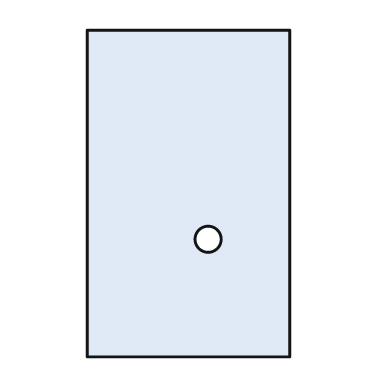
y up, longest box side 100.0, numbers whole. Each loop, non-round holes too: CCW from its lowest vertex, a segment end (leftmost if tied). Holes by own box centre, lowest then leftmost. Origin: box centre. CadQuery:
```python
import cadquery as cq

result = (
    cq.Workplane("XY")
    .moveTo(-31.0, -50.0)
    .lineTo(31.0, -50.0)
    .lineTo(31.0, 50.0)
    .lineTo(-31.0, 50.0)
    .close()
    .moveTo(6.0, -14.0)
    .circle(4.0)
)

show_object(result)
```